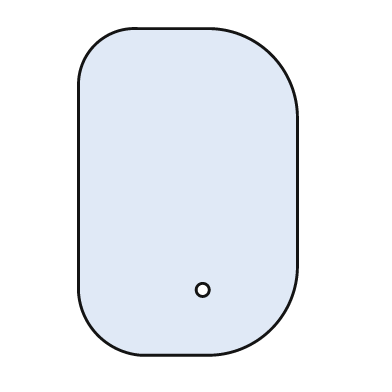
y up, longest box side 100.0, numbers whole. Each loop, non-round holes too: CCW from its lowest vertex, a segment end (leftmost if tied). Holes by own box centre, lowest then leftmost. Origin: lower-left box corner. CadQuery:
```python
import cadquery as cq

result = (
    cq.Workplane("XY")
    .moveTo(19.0, 0.0)
    .lineTo(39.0, 0.0)
    .threePointArc((59.0, 8.0), (67.0, 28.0))
    .lineTo(67.0, 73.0)
    .threePointArc((59.0, 92.0), (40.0, 100.0))
    .lineTo(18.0, 100.0)
    .threePointArc((5.0, 95.0), (0.0, 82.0))
    .lineTo(0.0, 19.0)
    .threePointArc((6.0, 6.0), (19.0, 0.0))
    .close()
    .moveTo(38.0, 20.0)
    .circle(2.0)
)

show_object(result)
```